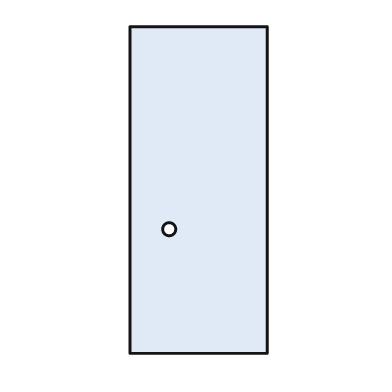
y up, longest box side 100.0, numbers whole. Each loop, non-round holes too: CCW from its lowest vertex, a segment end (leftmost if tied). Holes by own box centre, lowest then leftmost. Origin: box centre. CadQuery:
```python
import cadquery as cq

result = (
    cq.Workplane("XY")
    .moveTo(-21.0, -50.0)
    .lineTo(21.0, -50.0)
    .lineTo(21.0, 50.0)
    .lineTo(-21.0, 50.0)
    .close()
    .moveTo(-9.0, -12.0)
    .circle(2.0)
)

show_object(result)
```